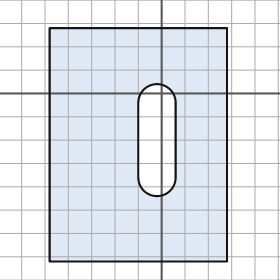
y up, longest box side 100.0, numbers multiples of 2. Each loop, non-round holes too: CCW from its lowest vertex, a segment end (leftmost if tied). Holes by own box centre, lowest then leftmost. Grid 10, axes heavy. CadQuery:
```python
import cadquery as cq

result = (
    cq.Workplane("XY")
    .moveTo(-48.0, -72.0)
    .lineTo(28.0, -72.0)
    .lineTo(28.0, 28.0)
    .lineTo(-48.0, 28.0)
    .close()
    .moveTo(-10.0, -36.0)
    .threePointArc((-2.0, -44.0), (6.0, -36.0))
    .lineTo(6.0, -4.0)
    .threePointArc((-2.0, 4.0), (-10.0, -4.0))
    .close()
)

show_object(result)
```